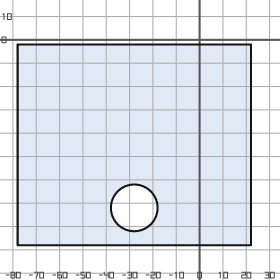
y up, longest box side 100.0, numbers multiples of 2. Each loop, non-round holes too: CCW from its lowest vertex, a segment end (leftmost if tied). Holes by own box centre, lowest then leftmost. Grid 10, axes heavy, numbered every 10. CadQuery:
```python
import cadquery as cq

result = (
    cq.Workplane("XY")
    .moveTo(-78.0, -88.0)
    .lineTo(22.0, -88.0)
    .lineTo(22.0, -2.0)
    .lineTo(-78.0, -2.0)
    .close()
    .moveTo(-28.0, -72.0)
    .circle(10.0)
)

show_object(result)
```